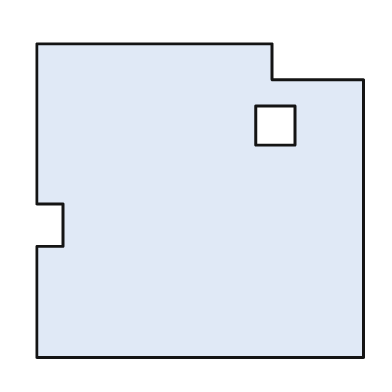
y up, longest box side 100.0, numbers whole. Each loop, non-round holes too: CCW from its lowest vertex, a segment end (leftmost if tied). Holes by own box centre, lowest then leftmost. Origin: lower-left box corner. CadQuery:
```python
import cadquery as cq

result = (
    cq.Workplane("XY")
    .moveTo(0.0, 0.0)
    .lineTo(100.0, 0.0)
    .lineTo(100.0, 85.0)
    .lineTo(72.0, 85.0)
    .lineTo(72.0, 96.0)
    .lineTo(0.0, 96.0)
    .lineTo(0.0, 47.0)
    .lineTo(8.0, 47.0)
    .lineTo(8.0, 34.0)
    .lineTo(0.0, 34.0)
    .close()
    .moveTo(67.0, 65.0)
    .lineTo(79.0, 65.0)
    .lineTo(79.0, 77.0)
    .lineTo(67.0, 77.0)
    .close()
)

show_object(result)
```